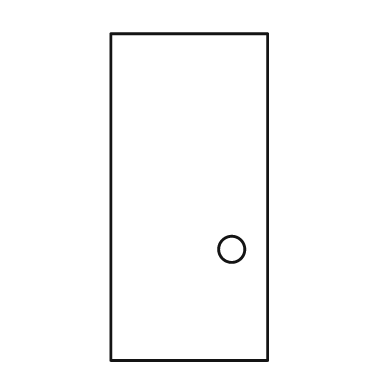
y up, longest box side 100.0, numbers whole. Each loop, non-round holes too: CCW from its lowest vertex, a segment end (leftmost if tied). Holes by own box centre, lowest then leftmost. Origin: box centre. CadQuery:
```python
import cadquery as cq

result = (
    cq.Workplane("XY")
    .moveTo(-24.0, -50.0)
    .lineTo(24.0, -50.0)
    .lineTo(24.0, 50.0)
    .lineTo(-24.0, 50.0)
    .close()
    .moveTo(13.0, -16.0)
    .circle(4.0)
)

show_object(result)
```